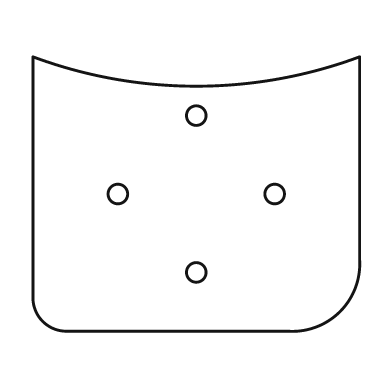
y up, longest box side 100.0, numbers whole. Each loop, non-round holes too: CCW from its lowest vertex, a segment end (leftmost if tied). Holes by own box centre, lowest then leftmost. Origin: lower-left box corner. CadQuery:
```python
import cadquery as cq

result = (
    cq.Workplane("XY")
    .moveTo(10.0, 0.0)
    .lineTo(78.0, 0.0)
    .threePointArc((94.0, 6.0), (100.0, 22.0))
    .lineTo(100.0, 84.0)
    .threePointArc((50.0, 75.0), (0.0, 84.0))
    .lineTo(0.0, 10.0)
    .threePointArc((3.0, 3.0), (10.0, 0.0))
    .close()
    .moveTo(50.0, 18.0)
    .circle(3.0)
    .moveTo(26.0, 42.0)
    .circle(3.0)
    .moveTo(74.0, 42.0)
    .circle(3.0)
    .moveTo(50.0, 66.0)
    .circle(3.0)
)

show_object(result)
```